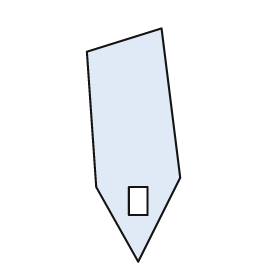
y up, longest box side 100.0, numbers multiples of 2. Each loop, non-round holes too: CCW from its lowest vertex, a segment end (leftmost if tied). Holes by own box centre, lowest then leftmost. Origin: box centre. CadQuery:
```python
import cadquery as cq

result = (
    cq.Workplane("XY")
    .moveTo(2.0, -50.0)
    .lineTo(20.0, -14.0)
    .lineTo(12.0, 50.0)
    .lineTo(-20.0, 40.0)
    .lineTo(-16.0, -18.0)
    .close()
    .moveTo(-2.0, -30.0)
    .lineTo(6.0, -30.0)
    .lineTo(6.0, -18.0)
    .lineTo(-2.0, -18.0)
    .close()
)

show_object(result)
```